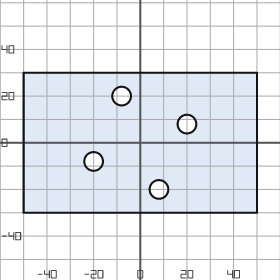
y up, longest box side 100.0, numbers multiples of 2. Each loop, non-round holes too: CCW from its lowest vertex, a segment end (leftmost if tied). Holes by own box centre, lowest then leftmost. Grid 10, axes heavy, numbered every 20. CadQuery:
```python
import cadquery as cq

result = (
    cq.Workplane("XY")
    .moveTo(-50.0, -30.0)
    .lineTo(50.0, -30.0)
    .lineTo(50.0, 30.0)
    .lineTo(-50.0, 30.0)
    .close()
    .moveTo(8.0, -20.0)
    .circle(4.0)
    .moveTo(-20.0, -8.0)
    .circle(4.0)
    .moveTo(20.0, 8.0)
    .circle(4.0)
    .moveTo(-8.0, 20.0)
    .circle(4.0)
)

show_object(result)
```